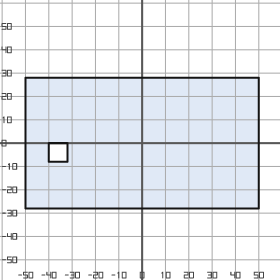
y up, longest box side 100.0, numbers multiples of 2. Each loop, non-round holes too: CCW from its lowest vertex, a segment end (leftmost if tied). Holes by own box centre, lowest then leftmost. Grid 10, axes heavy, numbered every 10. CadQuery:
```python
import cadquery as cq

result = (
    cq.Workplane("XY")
    .moveTo(-50.0, -28.0)
    .lineTo(50.0, -28.0)
    .lineTo(50.0, 28.0)
    .lineTo(-50.0, 28.0)
    .close()
    .moveTo(-40.0, -8.0)
    .lineTo(-32.0, -8.0)
    .lineTo(-32.0, 0.0)
    .lineTo(-40.0, 0.0)
    .close()
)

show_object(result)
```